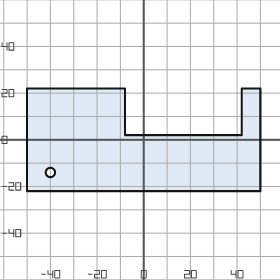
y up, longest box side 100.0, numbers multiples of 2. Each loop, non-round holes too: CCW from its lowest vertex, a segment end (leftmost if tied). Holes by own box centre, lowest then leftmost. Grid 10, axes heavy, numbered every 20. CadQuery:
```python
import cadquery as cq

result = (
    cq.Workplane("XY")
    .moveTo(-50.0, -22.0)
    .lineTo(50.0, -22.0)
    .lineTo(50.0, 22.0)
    .lineTo(42.0, 22.0)
    .lineTo(42.0, 2.0)
    .lineTo(-8.0, 2.0)
    .lineTo(-8.0, 22.0)
    .lineTo(-50.0, 22.0)
    .close()
    .moveTo(-40.0, -14.0)
    .circle(2.0)
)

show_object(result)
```